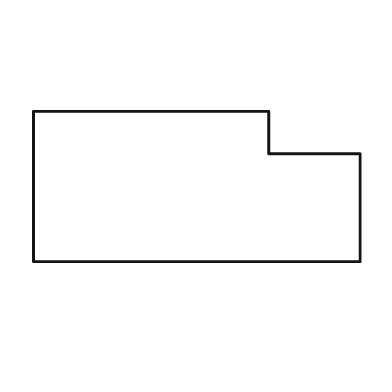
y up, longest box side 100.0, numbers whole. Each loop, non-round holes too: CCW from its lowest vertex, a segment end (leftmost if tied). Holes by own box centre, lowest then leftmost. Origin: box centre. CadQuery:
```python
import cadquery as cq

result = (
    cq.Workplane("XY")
    .moveTo(-50.0, -23.0)
    .lineTo(50.0, -23.0)
    .lineTo(50.0, 10.0)
    .lineTo(22.0, 10.0)
    .lineTo(22.0, 23.0)
    .lineTo(-50.0, 23.0)
    .close()
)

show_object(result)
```